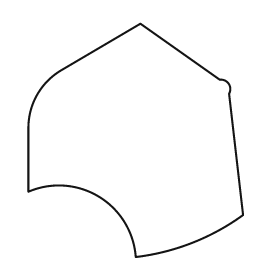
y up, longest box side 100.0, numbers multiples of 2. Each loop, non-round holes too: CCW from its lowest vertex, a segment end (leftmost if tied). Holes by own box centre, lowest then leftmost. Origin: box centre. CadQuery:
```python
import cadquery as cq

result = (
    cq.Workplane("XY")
    .moveTo(0.0, -50.0)
    .threePointArc((24.0, -44.0), (46.0, -32.0))
    .lineTo(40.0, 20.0)
    .threePointArc((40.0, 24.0), (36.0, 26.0))
    .lineTo(2.0, 50.0)
    .lineTo(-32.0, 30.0)
    .threePointArc((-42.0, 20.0), (-46.0, 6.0))
    .lineTo(-46.0, -22.0)
    .threePointArc((-16.0, -24.0), (0.0, -50.0))
    .close()
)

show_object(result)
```